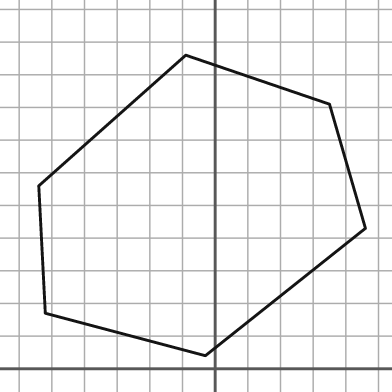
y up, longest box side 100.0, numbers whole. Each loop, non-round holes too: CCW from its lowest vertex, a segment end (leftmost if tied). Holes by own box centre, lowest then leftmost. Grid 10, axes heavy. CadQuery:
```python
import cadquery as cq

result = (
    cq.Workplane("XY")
    .moveTo(-3.0, 4.0)
    .lineTo(46.0, 43.0)
    .lineTo(35.0, 81.0)
    .lineTo(-9.0, 96.0)
    .lineTo(-54.0, 56.0)
    .lineTo(-52.0, 17.0)
    .close()
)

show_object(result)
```